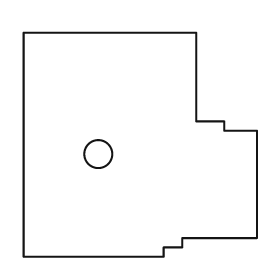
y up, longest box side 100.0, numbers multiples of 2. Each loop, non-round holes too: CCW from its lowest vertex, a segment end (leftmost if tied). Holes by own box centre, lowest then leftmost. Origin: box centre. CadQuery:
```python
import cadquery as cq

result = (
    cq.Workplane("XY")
    .moveTo(-50.0, -48.0)
    .lineTo(10.0, -48.0)
    .lineTo(10.0, -44.0)
    .lineTo(18.0, -44.0)
    .lineTo(18.0, -40.0)
    .lineTo(50.0, -40.0)
    .lineTo(50.0, 6.0)
    .lineTo(36.0, 6.0)
    .lineTo(36.0, 10.0)
    .lineTo(24.0, 10.0)
    .lineTo(24.0, 48.0)
    .lineTo(-50.0, 48.0)
    .close()
    .moveTo(-18.0, -4.0)
    .circle(6.0)
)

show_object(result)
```